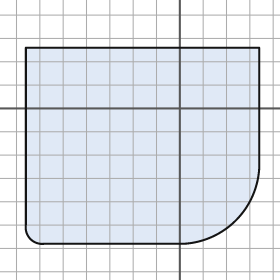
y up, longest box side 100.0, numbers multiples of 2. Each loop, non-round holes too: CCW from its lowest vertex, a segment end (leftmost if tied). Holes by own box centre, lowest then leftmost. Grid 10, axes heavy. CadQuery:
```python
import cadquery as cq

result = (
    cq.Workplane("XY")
    .moveTo(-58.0, -58.0)
    .lineTo(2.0, -58.0)
    .threePointArc((24.0, -48.0), (34.0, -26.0))
    .lineTo(34.0, 26.0)
    .lineTo(-66.0, 26.0)
    .lineTo(-66.0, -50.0)
    .threePointArc((-64.0, -56.0), (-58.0, -58.0))
    .close()
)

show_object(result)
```